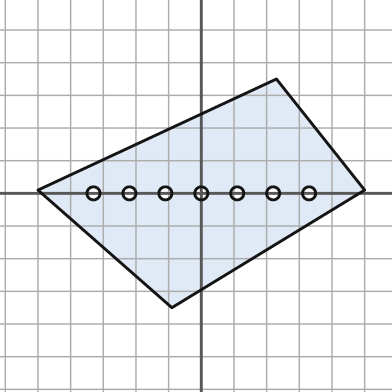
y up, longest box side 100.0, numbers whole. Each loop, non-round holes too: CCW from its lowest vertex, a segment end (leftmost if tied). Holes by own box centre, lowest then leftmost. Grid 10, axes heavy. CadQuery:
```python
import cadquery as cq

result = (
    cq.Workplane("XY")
    .moveTo(-9.0, -35.0)
    .lineTo(50.0, 1.0)
    .lineTo(23.0, 35.0)
    .lineTo(-50.0, 1.0)
    .close()
    .moveTo(-33.0, 0.0)
    .circle(2.0)
    .moveTo(-22.0, 0.0)
    .circle(2.0)
    .moveTo(-11.0, 0.0)
    .circle(2.0)
    .moveTo(0.0, 0.0)
    .circle(2.0)
    .moveTo(11.0, 0.0)
    .circle(2.0)
    .moveTo(22.0, 0.0)
    .circle(2.0)
    .moveTo(33.0, 0.0)
    .circle(2.0)
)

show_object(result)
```